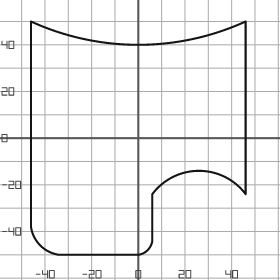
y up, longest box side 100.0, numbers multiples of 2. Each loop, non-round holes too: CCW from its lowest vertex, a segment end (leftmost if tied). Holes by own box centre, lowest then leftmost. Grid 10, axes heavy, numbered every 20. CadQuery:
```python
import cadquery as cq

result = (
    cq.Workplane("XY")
    .moveTo(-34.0, -50.0)
    .lineTo(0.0, -50.0)
    .threePointArc((4.0, -48.0), (6.0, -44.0))
    .lineTo(6.0, -24.0)
    .threePointArc((26.0, -14.0), (46.0, -24.0))
    .lineTo(46.0, 50.0)
    .threePointArc((0.0, 40.0), (-46.0, 50.0))
    .lineTo(-46.0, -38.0)
    .threePointArc((-42.0, -46.0), (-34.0, -50.0))
    .close()
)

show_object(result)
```